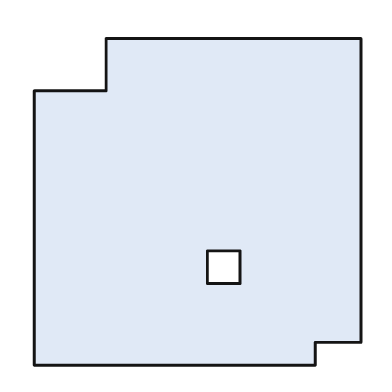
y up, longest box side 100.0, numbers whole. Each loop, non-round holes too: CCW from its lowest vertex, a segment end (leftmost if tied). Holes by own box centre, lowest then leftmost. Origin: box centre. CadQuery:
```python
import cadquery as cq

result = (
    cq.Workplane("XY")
    .moveTo(-50.0, -50.0)
    .lineTo(36.0, -50.0)
    .lineTo(36.0, -43.0)
    .lineTo(50.0, -43.0)
    .lineTo(50.0, 50.0)
    .lineTo(-28.0, 50.0)
    .lineTo(-28.0, 34.0)
    .lineTo(-50.0, 34.0)
    .close()
    .moveTo(3.0, -25.0)
    .lineTo(13.0, -25.0)
    .lineTo(13.0, -15.0)
    .lineTo(3.0, -15.0)
    .close()
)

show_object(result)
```